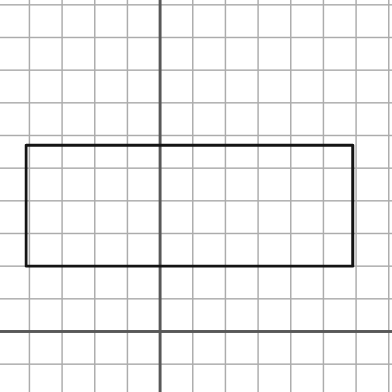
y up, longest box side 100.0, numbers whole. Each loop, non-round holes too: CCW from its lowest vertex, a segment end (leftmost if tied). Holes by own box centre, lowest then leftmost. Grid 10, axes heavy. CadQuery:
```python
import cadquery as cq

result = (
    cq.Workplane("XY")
    .moveTo(-41.0, 20.0)
    .lineTo(59.0, 20.0)
    .lineTo(59.0, 57.0)
    .lineTo(-41.0, 57.0)
    .close()
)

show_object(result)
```